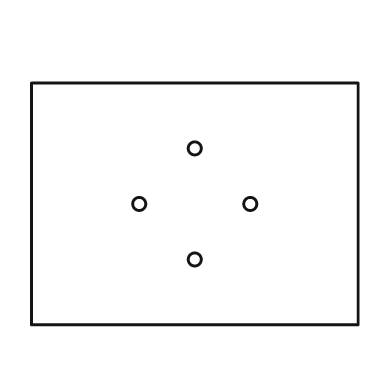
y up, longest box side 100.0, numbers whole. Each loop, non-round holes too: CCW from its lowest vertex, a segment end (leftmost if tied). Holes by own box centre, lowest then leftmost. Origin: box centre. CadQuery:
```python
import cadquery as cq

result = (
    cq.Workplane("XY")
    .moveTo(-50.0, -37.0)
    .lineTo(50.0, -37.0)
    .lineTo(50.0, 37.0)
    .lineTo(-50.0, 37.0)
    .close()
    .moveTo(0.0, -17.0)
    .circle(2.0)
    .moveTo(-17.0, 0.0)
    .circle(2.0)
    .moveTo(17.0, 0.0)
    .circle(2.0)
    .moveTo(0.0, 17.0)
    .circle(2.0)
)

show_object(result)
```